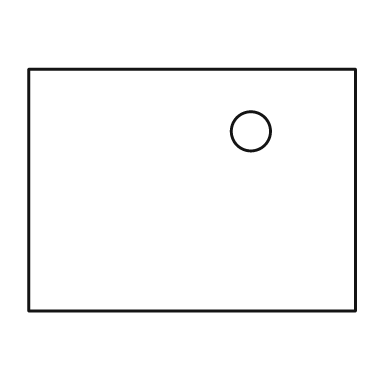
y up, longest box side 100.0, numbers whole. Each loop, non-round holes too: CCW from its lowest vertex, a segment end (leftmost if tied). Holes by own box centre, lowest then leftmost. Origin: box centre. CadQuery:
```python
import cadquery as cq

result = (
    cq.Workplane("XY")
    .moveTo(-50.0, -37.0)
    .lineTo(50.0, -37.0)
    .lineTo(50.0, 37.0)
    .lineTo(-50.0, 37.0)
    .close()
    .moveTo(18.0, 18.0)
    .circle(6.0)
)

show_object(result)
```